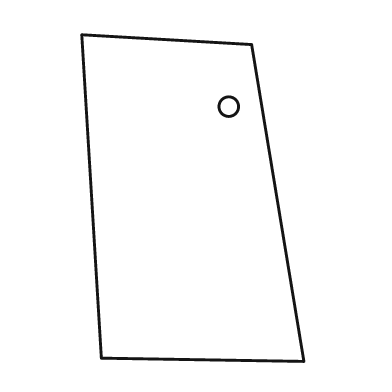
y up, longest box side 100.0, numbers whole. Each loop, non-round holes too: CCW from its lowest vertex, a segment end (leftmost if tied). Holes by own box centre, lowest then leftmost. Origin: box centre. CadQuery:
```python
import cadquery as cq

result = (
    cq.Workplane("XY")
    .moveTo(34.0, -50.0)
    .lineTo(18.0, 47.0)
    .lineTo(-34.0, 50.0)
    .lineTo(-28.0, -49.0)
    .close()
    .moveTo(11.0, 28.0)
    .circle(3.0)
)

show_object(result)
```